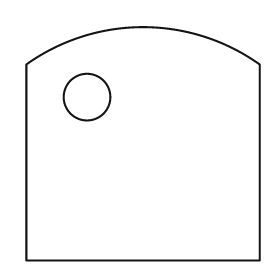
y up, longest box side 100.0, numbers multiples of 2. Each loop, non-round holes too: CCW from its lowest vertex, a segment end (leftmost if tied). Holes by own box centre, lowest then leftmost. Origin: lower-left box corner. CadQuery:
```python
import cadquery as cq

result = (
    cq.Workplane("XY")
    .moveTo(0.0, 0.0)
    .lineTo(100.0, 0.0)
    .lineTo(100.0, 84.0)
    .threePointArc((50.0, 100.0), (0.0, 84.0))
    .close()
    .moveTo(26.0, 70.0)
    .circle(10.0)
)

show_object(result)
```